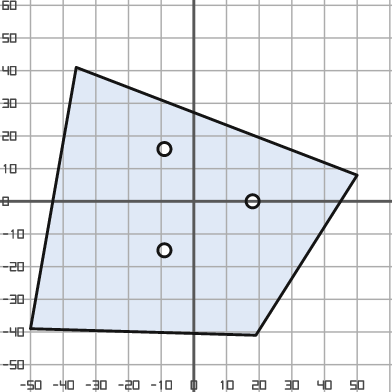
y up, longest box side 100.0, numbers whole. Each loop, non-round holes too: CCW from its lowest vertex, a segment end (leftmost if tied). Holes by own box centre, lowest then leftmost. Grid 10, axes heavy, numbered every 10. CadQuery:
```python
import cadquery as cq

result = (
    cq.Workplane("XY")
    .moveTo(19.0, -41.0)
    .lineTo(50.0, 8.0)
    .lineTo(-36.0, 41.0)
    .lineTo(-50.0, -39.0)
    .close()
    .moveTo(-9.0, -15.0)
    .circle(2.0)
    .moveTo(18.0, 0.0)
    .circle(2.0)
    .moveTo(-9.0, 16.0)
    .circle(2.0)
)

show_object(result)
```